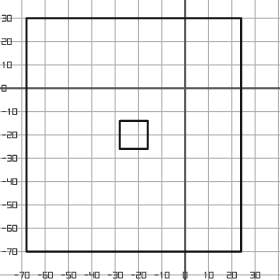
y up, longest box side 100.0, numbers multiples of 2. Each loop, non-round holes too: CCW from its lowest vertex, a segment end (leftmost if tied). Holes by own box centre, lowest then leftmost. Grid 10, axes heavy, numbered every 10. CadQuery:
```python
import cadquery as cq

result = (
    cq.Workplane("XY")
    .moveTo(-68.0, -70.0)
    .lineTo(24.0, -70.0)
    .lineTo(24.0, 30.0)
    .lineTo(-68.0, 30.0)
    .close()
    .moveTo(-28.0, -26.0)
    .lineTo(-16.0, -26.0)
    .lineTo(-16.0, -14.0)
    .lineTo(-28.0, -14.0)
    .close()
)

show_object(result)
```